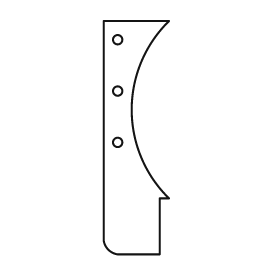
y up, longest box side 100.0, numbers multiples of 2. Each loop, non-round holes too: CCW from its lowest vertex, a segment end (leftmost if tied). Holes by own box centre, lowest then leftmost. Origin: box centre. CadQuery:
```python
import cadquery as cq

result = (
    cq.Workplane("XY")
    .moveTo(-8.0, -50.0)
    .lineTo(10.0, -50.0)
    .lineTo(10.0, -26.0)
    .lineTo(14.0, -26.0)
    .threePointArc((-2.0, 12.0), (14.0, 50.0))
    .lineTo(-14.0, 50.0)
    .lineTo(-14.0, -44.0)
    .threePointArc((-12.0, -48.0), (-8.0, -50.0))
    .close()
    .moveTo(-8.0, -2.0)
    .circle(2.0)
    .moveTo(-8.0, 20.0)
    .circle(2.0)
    .moveTo(-8.0, 42.0)
    .circle(2.0)
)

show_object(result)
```